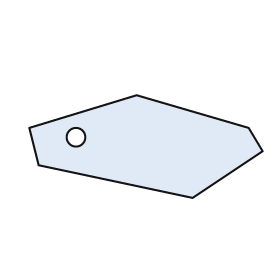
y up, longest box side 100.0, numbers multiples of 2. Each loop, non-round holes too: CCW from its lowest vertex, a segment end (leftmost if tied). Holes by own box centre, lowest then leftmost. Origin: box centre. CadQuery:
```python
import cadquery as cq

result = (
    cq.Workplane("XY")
    .moveTo(20.0, -22.0)
    .lineTo(50.0, -2.0)
    .lineTo(44.0, 8.0)
    .lineTo(-4.0, 22.0)
    .lineTo(-50.0, 8.0)
    .lineTo(-46.0, -8.0)
    .close()
    .moveTo(-30.0, 4.0)
    .circle(4.0)
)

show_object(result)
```